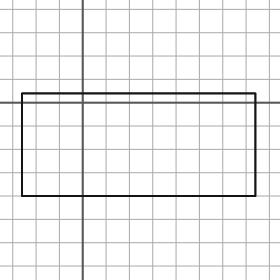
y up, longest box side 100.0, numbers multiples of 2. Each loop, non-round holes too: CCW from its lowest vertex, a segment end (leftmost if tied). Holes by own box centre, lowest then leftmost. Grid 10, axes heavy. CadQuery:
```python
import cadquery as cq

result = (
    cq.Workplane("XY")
    .moveTo(-26.0, -40.0)
    .lineTo(74.0, -40.0)
    .lineTo(74.0, 4.0)
    .lineTo(-26.0, 4.0)
    .close()
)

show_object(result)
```